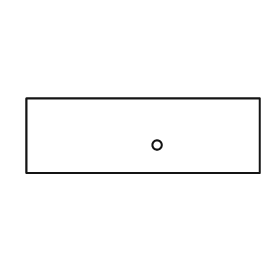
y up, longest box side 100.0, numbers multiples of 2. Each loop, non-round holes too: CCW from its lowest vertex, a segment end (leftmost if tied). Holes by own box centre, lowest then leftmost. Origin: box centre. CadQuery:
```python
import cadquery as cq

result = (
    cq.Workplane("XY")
    .moveTo(-50.0, -16.0)
    .lineTo(50.0, -16.0)
    .lineTo(50.0, 16.0)
    .lineTo(-50.0, 16.0)
    .close()
    .moveTo(6.0, -4.0)
    .circle(2.0)
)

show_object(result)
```